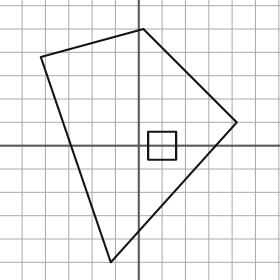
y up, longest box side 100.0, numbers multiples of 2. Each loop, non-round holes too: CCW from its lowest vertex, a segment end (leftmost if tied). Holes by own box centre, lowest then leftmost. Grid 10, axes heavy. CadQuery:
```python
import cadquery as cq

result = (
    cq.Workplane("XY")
    .moveTo(-12.0, -50.0)
    .lineTo(42.0, 10.0)
    .lineTo(2.0, 50.0)
    .lineTo(-42.0, 38.0)
    .close()
    .moveTo(4.0, -6.0)
    .lineTo(16.0, -6.0)
    .lineTo(16.0, 6.0)
    .lineTo(4.0, 6.0)
    .close()
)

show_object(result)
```